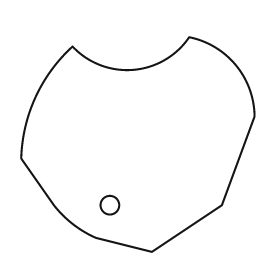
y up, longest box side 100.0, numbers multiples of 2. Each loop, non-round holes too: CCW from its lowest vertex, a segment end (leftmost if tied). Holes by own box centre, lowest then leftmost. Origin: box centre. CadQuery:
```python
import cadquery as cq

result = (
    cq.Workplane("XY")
    .moveTo(6.0, -46.0)
    .lineTo(36.0, -26.0)
    .lineTo(50.0, 12.0)
    .threePointArc((42.0, 34.0), (22.0, 46.0))
    .threePointArc((-2.0, 32.0), (-28.0, 42.0))
    .threePointArc((-44.0, 20.0), (-50.0, -6.0))
    .lineTo(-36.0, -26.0)
    .threePointArc((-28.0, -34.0), (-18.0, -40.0))
    .close()
    .moveTo(-12.0, -26.0)
    .circle(4.0)
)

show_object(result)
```